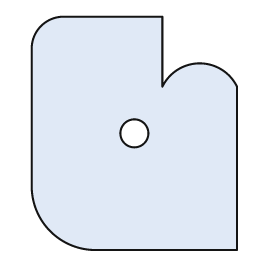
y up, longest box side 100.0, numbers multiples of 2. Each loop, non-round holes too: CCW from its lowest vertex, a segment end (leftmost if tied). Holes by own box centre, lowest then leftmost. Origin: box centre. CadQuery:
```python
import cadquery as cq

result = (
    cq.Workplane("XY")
    .moveTo(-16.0, -50.0)
    .lineTo(44.0, -50.0)
    .lineTo(44.0, 20.0)
    .threePointArc((28.0, 30.0), (12.0, 20.0))
    .lineTo(12.0, 50.0)
    .lineTo(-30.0, 50.0)
    .threePointArc((-40.0, 46.0), (-44.0, 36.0))
    .lineTo(-44.0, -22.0)
    .threePointArc((-36.0, -42.0), (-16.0, -50.0))
    .close()
    .moveTo(0.0, 0.0)
    .circle(6.0)
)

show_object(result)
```